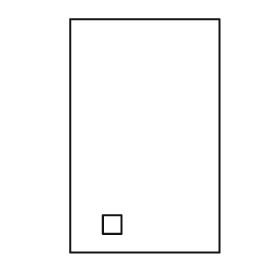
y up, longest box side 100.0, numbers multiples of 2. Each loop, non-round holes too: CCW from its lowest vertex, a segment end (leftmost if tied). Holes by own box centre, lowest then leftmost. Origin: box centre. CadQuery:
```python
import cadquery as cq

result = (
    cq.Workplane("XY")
    .moveTo(-32.0, -50.0)
    .lineTo(32.0, -50.0)
    .lineTo(32.0, 50.0)
    .lineTo(-32.0, 50.0)
    .close()
    .moveTo(-18.0, -42.0)
    .lineTo(-10.0, -42.0)
    .lineTo(-10.0, -34.0)
    .lineTo(-18.0, -34.0)
    .close()
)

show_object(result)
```